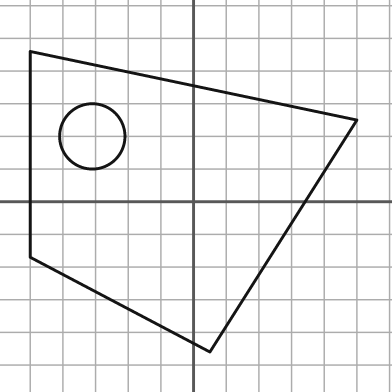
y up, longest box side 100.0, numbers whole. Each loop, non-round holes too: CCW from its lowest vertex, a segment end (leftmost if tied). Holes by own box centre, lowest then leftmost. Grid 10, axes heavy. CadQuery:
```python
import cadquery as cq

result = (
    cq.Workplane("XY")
    .moveTo(5.0, -46.0)
    .lineTo(50.0, 25.0)
    .lineTo(-50.0, 46.0)
    .lineTo(-50.0, -17.0)
    .close()
    .moveTo(-31.0, 20.0)
    .circle(10.0)
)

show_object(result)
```